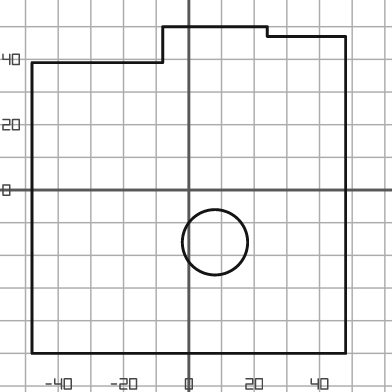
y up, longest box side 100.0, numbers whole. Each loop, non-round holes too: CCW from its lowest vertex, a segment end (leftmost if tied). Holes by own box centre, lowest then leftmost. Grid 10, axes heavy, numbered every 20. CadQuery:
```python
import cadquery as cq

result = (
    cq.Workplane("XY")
    .moveTo(-48.0, -50.0)
    .lineTo(48.0, -50.0)
    .lineTo(48.0, 47.0)
    .lineTo(24.0, 47.0)
    .lineTo(24.0, 50.0)
    .lineTo(-8.0, 50.0)
    .lineTo(-8.0, 39.0)
    .lineTo(-48.0, 39.0)
    .close()
    .moveTo(8.0, -16.0)
    .circle(10.0)
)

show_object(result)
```